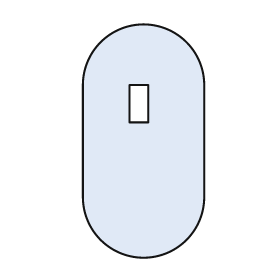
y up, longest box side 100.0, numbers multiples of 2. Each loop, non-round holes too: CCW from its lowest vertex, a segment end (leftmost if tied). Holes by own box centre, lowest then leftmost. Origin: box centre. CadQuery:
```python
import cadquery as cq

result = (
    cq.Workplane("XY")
    .moveTo(-26.0, -24.0)
    .threePointArc((0.0, -50.0), (26.0, -24.0))
    .lineTo(26.0, 24.0)
    .threePointArc((0.0, 50.0), (-26.0, 24.0))
    .close()
    .moveTo(-6.0, 8.0)
    .lineTo(2.0, 8.0)
    .lineTo(2.0, 24.0)
    .lineTo(-6.0, 24.0)
    .close()
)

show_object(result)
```